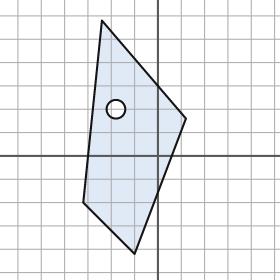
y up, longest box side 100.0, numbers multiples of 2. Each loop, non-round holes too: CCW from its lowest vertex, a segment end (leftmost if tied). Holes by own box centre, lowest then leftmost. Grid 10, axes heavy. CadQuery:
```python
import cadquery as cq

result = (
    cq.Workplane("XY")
    .moveTo(-10.0, -42.0)
    .lineTo(12.0, 16.0)
    .lineTo(-24.0, 58.0)
    .lineTo(-32.0, -20.0)
    .close()
    .moveTo(-18.0, 20.0)
    .circle(4.0)
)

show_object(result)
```